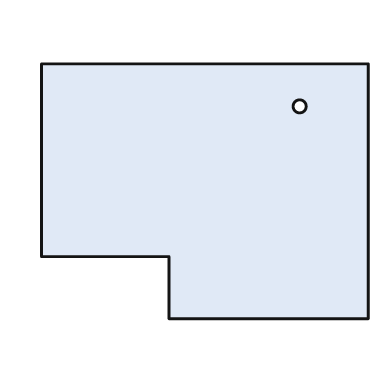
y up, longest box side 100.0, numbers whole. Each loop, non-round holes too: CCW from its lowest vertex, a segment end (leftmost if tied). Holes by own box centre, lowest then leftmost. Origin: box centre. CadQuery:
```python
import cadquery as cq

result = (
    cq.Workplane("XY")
    .moveTo(-11.0, -39.0)
    .lineTo(50.0, -39.0)
    .lineTo(50.0, 39.0)
    .lineTo(-50.0, 39.0)
    .lineTo(-50.0, -20.0)
    .lineTo(-11.0, -20.0)
    .close()
    .moveTo(29.0, 26.0)
    .circle(2.0)
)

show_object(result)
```